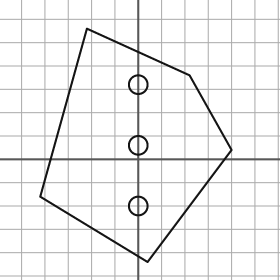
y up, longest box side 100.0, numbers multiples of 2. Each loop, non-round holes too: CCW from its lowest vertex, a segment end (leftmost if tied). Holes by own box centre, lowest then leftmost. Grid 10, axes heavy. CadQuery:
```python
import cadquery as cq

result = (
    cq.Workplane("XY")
    .moveTo(4.0, -44.0)
    .lineTo(40.0, 4.0)
    .lineTo(22.0, 36.0)
    .lineTo(-22.0, 56.0)
    .lineTo(-42.0, -16.0)
    .close()
    .moveTo(0.0, -20.0)
    .circle(4.0)
    .moveTo(0.0, 6.0)
    .circle(4.0)
    .moveTo(0.0, 32.0)
    .circle(4.0)
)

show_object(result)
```